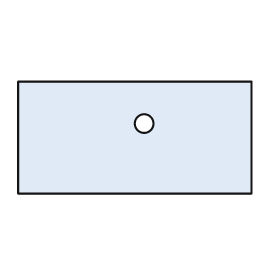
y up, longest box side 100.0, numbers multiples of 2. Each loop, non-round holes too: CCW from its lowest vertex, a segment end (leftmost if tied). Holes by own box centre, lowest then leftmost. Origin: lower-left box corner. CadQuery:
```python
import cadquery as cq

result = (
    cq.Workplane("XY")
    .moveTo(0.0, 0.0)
    .lineTo(100.0, 0.0)
    .lineTo(100.0, 48.0)
    .lineTo(0.0, 48.0)
    .close()
    .moveTo(54.0, 30.0)
    .circle(4.0)
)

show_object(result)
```